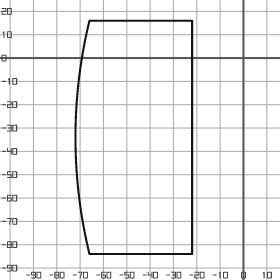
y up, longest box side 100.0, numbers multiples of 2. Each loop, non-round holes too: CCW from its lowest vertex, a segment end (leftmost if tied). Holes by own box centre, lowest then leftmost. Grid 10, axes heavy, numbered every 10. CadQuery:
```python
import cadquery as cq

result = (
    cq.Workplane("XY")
    .moveTo(-66.0, -84.0)
    .lineTo(-22.0, -84.0)
    .lineTo(-22.0, 16.0)
    .lineTo(-66.0, 16.0)
    .threePointArc((-72.0, -34.0), (-66.0, -84.0))
    .close()
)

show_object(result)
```